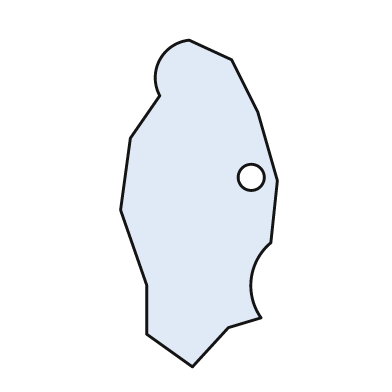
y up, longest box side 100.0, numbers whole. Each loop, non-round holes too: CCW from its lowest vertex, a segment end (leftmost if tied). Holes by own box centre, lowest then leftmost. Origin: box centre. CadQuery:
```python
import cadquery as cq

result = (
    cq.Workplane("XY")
    .moveTo(-2.0, -50.0)
    .lineTo(9.0, -38.0)
    .lineTo(19.0, -35.0)
    .threePointArc((16.0, -23.0), (22.0, -12.0))
    .lineTo(24.0, 7.0)
    .lineTo(18.0, 28.0)
    .lineTo(10.0, 44.0)
    .lineTo(-3.0, 50.0)
    .threePointArc((-12.0, 44.0), (-12.0, 33.0))
    .lineTo(-21.0, 20.0)
    .lineTo(-24.0, -2.0)
    .lineTo(-16.0, -25.0)
    .lineTo(-16.0, -40.0)
    .close()
    .moveTo(16.0, 8.0)
    .circle(4.0)
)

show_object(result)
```